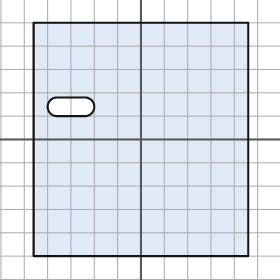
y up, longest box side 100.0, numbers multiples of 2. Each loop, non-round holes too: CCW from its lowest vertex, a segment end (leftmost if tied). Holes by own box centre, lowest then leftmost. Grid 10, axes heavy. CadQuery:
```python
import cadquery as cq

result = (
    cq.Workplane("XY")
    .moveTo(-46.0, -50.0)
    .lineTo(46.0, -50.0)
    .lineTo(46.0, 50.0)
    .lineTo(-46.0, 50.0)
    .close()
    .moveTo(-36.0, 10.0)
    .lineTo(-24.0, 10.0)
    .threePointArc((-20.0, 14.0), (-24.0, 18.0))
    .lineTo(-36.0, 18.0)
    .threePointArc((-40.0, 14.0), (-36.0, 10.0))
    .close()
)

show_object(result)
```